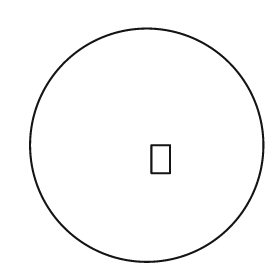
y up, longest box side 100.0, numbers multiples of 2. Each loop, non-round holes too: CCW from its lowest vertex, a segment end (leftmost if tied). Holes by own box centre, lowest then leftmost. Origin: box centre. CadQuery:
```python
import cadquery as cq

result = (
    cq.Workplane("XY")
    .moveTo(0.0, 0.0)
    .circle(50.0)
    .moveTo(2.0, -12.0)
    .lineTo(10.0, -12.0)
    .lineTo(10.0, 0.0)
    .lineTo(2.0, 0.0)
    .close()
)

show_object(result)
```